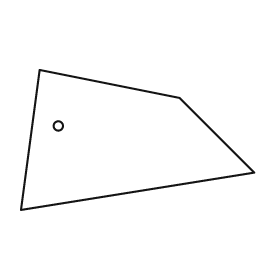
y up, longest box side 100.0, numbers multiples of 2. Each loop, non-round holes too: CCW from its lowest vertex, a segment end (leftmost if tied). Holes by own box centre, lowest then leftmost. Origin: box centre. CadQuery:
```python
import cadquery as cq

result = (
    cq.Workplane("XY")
    .moveTo(-50.0, -30.0)
    .lineTo(50.0, -14.0)
    .lineTo(18.0, 18.0)
    .lineTo(-42.0, 30.0)
    .close()
    .moveTo(-34.0, 6.0)
    .circle(2.0)
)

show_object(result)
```